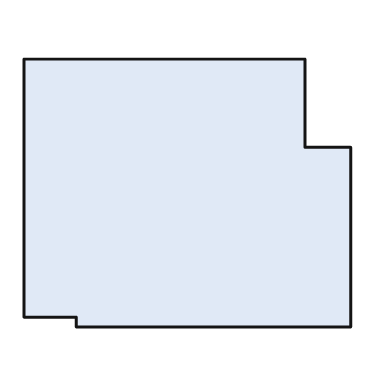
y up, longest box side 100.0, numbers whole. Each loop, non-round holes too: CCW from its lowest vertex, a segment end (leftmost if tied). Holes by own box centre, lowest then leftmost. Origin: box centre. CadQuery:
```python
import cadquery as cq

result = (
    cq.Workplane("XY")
    .moveTo(-34.0, -41.0)
    .lineTo(50.0, -41.0)
    .lineTo(50.0, 14.0)
    .lineTo(36.0, 14.0)
    .lineTo(36.0, 41.0)
    .lineTo(-50.0, 41.0)
    .lineTo(-50.0, -38.0)
    .lineTo(-34.0, -38.0)
    .close()
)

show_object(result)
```